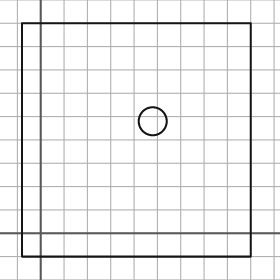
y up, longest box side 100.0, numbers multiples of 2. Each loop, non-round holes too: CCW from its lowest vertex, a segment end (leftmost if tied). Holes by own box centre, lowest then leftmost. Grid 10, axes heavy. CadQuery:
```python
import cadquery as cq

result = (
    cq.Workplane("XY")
    .moveTo(-8.0, -10.0)
    .lineTo(90.0, -10.0)
    .lineTo(90.0, 90.0)
    .lineTo(-8.0, 90.0)
    .close()
    .moveTo(48.0, 48.0)
    .circle(6.0)
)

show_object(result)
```